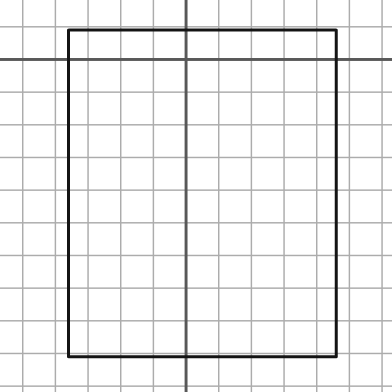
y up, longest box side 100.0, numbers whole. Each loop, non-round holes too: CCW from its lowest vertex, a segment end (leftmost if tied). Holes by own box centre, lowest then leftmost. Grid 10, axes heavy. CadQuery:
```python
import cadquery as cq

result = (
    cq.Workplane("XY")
    .moveTo(-36.0, -91.0)
    .lineTo(46.0, -91.0)
    .lineTo(46.0, 9.0)
    .lineTo(-36.0, 9.0)
    .close()
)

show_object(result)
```